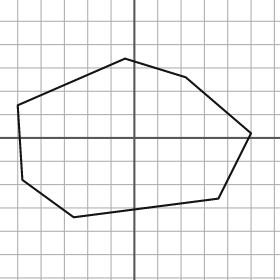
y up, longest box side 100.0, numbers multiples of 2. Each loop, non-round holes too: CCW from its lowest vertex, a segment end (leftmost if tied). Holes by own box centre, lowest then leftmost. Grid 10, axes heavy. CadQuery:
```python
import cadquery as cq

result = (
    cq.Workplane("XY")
    .moveTo(-26.0, -34.0)
    .lineTo(36.0, -26.0)
    .lineTo(50.0, 2.0)
    .lineTo(22.0, 26.0)
    .lineTo(-4.0, 34.0)
    .lineTo(-50.0, 14.0)
    .lineTo(-48.0, -18.0)
    .close()
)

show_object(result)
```